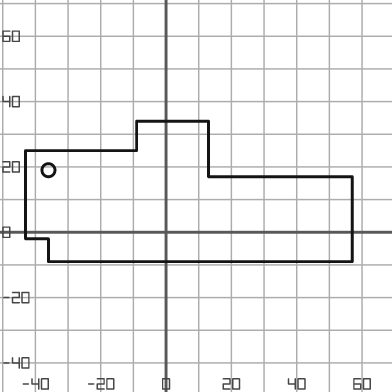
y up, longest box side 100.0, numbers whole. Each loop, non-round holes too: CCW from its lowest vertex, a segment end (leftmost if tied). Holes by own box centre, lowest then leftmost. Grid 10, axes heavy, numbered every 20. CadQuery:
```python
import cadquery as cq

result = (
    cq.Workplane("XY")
    .moveTo(-36.0, -9.0)
    .lineTo(57.0, -9.0)
    .lineTo(57.0, 17.0)
    .lineTo(13.0, 17.0)
    .lineTo(13.0, 34.0)
    .lineTo(-9.0, 34.0)
    .lineTo(-9.0, 25.0)
    .lineTo(-43.0, 25.0)
    .lineTo(-43.0, -2.0)
    .lineTo(-36.0, -2.0)
    .close()
    .moveTo(-36.0, 19.0)
    .circle(2.0)
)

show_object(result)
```